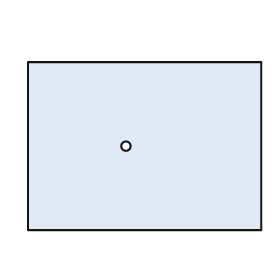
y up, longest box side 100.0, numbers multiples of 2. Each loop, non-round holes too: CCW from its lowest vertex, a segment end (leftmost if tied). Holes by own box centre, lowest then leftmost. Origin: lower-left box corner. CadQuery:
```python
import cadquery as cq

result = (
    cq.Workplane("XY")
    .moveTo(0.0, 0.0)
    .lineTo(100.0, 0.0)
    .lineTo(100.0, 72.0)
    .lineTo(0.0, 72.0)
    .close()
    .moveTo(42.0, 36.0)
    .circle(2.0)
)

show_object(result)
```